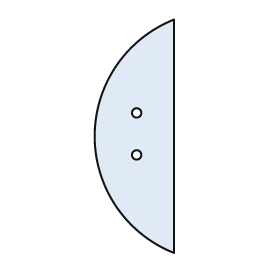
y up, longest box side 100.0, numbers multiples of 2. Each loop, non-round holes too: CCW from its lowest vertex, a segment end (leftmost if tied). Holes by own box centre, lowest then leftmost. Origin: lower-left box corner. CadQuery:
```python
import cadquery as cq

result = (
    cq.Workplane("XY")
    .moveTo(34.0, 0.0)
    .lineTo(34.0, 100.0)
    .threePointArc((0.0, 50.0), (34.0, 0.0))
    .close()
    .moveTo(18.0, 42.0)
    .circle(2.0)
    .moveTo(18.0, 60.0)
    .circle(2.0)
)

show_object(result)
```